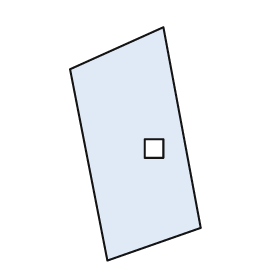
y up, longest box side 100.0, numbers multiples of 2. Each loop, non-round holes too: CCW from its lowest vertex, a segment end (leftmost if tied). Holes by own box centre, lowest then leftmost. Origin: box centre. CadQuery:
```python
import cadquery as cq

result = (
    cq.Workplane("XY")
    .moveTo(-12.0, -50.0)
    .lineTo(28.0, -36.0)
    .lineTo(12.0, 50.0)
    .lineTo(-28.0, 32.0)
    .close()
    .moveTo(4.0, -6.0)
    .lineTo(12.0, -6.0)
    .lineTo(12.0, 2.0)
    .lineTo(4.0, 2.0)
    .close()
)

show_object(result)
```